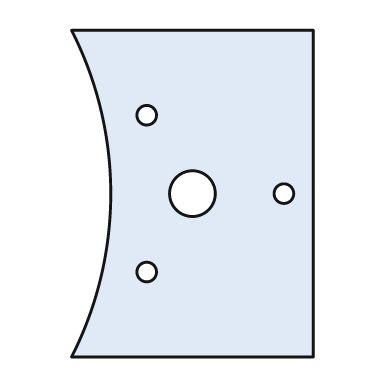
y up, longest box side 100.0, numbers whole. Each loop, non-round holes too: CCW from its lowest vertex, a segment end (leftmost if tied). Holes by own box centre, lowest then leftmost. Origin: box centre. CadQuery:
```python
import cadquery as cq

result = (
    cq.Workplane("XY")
    .moveTo(-37.0, -50.0)
    .lineTo(37.0, -50.0)
    .lineTo(37.0, 50.0)
    .lineTo(-37.0, 50.0)
    .threePointArc((-25.0, 0.0), (-37.0, -50.0))
    .close()
    .moveTo(-14.0, -24.0)
    .circle(3.0)
    .moveTo(0.0, 0.0)
    .circle(7.0)
    .moveTo(28.0, 0.0)
    .circle(3.0)
    .moveTo(-14.0, 24.0)
    .circle(3.0)
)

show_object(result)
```